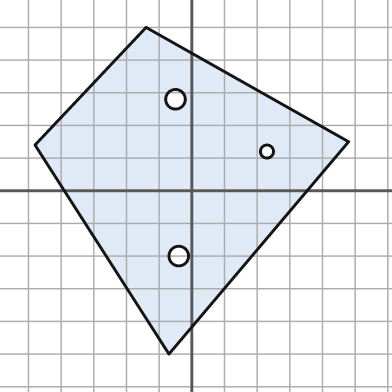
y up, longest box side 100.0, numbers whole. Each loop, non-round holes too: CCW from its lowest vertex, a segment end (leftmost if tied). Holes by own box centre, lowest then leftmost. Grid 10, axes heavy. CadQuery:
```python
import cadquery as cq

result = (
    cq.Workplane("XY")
    .moveTo(-7.0, -50.0)
    .lineTo(48.0, 15.0)
    .lineTo(-14.0, 50.0)
    .lineTo(-48.0, 14.0)
    .close()
    .moveTo(-4.0, -20.0)
    .circle(3.0)
    .moveTo(23.0, 12.0)
    .circle(2.0)
    .moveTo(-5.0, 28.0)
    .circle(3.0)
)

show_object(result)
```